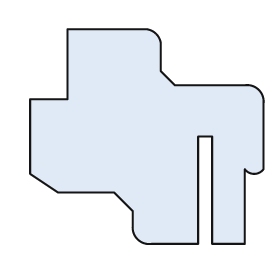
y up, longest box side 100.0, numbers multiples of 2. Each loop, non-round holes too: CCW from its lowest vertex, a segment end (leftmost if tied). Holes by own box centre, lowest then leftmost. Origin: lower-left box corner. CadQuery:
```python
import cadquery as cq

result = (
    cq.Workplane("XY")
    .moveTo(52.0, 0.0)
    .lineTo(72.0, 0.0)
    .lineTo(72.0, 46.0)
    .lineTo(78.0, 46.0)
    .lineTo(78.0, 0.0)
    .lineTo(92.0, 0.0)
    .lineTo(92.0, 32.0)
    .threePointArc((96.0, 30.0), (100.0, 32.0))
    .lineTo(100.0, 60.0)
    .threePointArc((98.0, 66.0), (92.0, 68.0))
    .lineTo(62.0, 68.0)
    .lineTo(56.0, 74.0)
    .lineTo(56.0, 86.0)
    .threePointArc((54.0, 90.0), (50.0, 92.0))
    .lineTo(16.0, 92.0)
    .lineTo(16.0, 62.0)
    .lineTo(0.0, 62.0)
    .lineTo(0.0, 30.0)
    .lineTo(12.0, 22.0)
    .lineTo(36.0, 22.0)
    .lineTo(44.0, 14.0)
    .lineTo(44.0, 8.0)
    .threePointArc((46.0, 2.0), (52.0, 0.0))
    .close()
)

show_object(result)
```